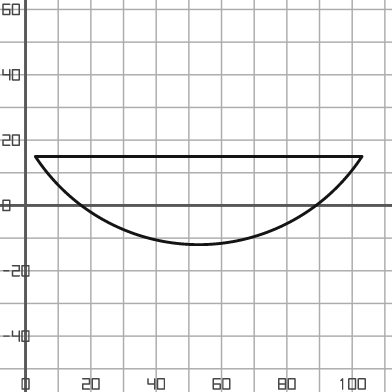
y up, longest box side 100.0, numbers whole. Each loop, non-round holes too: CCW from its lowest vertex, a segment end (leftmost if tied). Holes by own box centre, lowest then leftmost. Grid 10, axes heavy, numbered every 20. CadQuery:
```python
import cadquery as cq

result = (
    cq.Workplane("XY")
    .moveTo(3.0, 15.0)
    .threePointArc((53.0, -12.0), (103.0, 15.0))
    .close()
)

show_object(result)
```